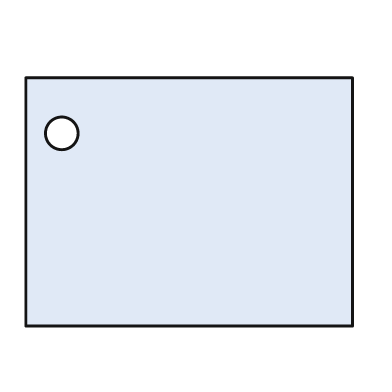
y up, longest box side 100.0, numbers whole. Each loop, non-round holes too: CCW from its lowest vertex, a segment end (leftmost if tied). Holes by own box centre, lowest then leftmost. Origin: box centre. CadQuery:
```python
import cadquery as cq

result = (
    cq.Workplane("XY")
    .moveTo(-50.0, -38.0)
    .lineTo(50.0, -38.0)
    .lineTo(50.0, 38.0)
    .lineTo(-50.0, 38.0)
    .close()
    .moveTo(-39.0, 21.0)
    .circle(5.0)
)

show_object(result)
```